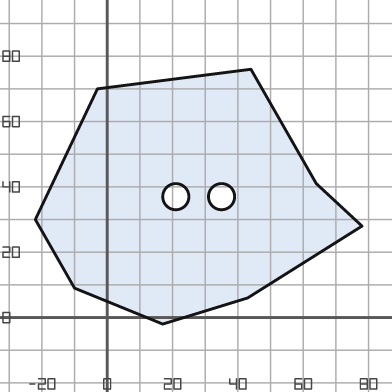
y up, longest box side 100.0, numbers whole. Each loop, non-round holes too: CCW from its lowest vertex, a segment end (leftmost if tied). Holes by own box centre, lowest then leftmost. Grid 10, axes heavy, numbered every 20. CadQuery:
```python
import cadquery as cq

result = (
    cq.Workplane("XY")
    .moveTo(17.0, -2.0)
    .lineTo(43.0, 6.0)
    .lineTo(78.0, 28.0)
    .lineTo(64.0, 41.0)
    .lineTo(44.0, 76.0)
    .lineTo(-3.0, 70.0)
    .lineTo(-22.0, 30.0)
    .lineTo(-10.0, 9.0)
    .close()
    .moveTo(21.0, 37.0)
    .circle(4.0)
    .moveTo(35.0, 37.0)
    .circle(4.0)
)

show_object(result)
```